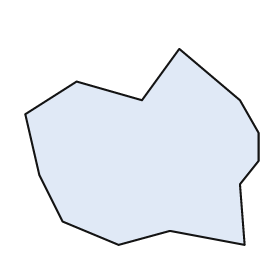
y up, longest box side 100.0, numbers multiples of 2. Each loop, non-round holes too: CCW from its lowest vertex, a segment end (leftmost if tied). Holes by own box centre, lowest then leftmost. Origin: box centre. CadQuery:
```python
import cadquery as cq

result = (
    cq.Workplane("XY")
    .moveTo(-10.0, -42.0)
    .lineTo(12.0, -36.0)
    .lineTo(44.0, -42.0)
    .lineTo(42.0, -16.0)
    .lineTo(50.0, -6.0)
    .lineTo(50.0, 6.0)
    .lineTo(42.0, 20.0)
    .lineTo(16.0, 42.0)
    .lineTo(0.0, 20.0)
    .lineTo(-28.0, 28.0)
    .lineTo(-50.0, 14.0)
    .lineTo(-44.0, -12.0)
    .lineTo(-34.0, -32.0)
    .close()
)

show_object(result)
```